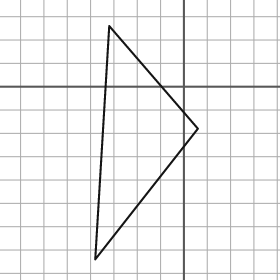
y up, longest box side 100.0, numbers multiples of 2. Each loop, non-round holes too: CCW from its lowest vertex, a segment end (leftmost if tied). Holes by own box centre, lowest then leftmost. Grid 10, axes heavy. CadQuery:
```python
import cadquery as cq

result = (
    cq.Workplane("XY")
    .moveTo(-38.0, -74.0)
    .lineTo(6.0, -18.0)
    .lineTo(-32.0, 26.0)
    .close()
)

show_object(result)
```